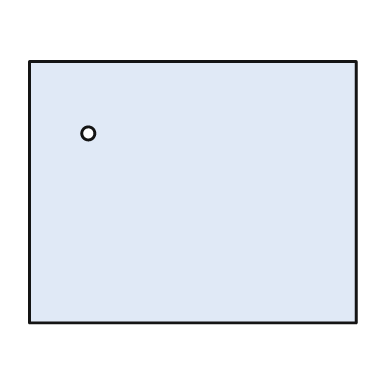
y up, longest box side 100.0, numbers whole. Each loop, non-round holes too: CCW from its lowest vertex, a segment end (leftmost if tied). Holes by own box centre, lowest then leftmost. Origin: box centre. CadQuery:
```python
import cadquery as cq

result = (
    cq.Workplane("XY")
    .moveTo(-50.0, -40.0)
    .lineTo(50.0, -40.0)
    .lineTo(50.0, 40.0)
    .lineTo(-50.0, 40.0)
    .close()
    .moveTo(-32.0, 18.0)
    .circle(2.0)
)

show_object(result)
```